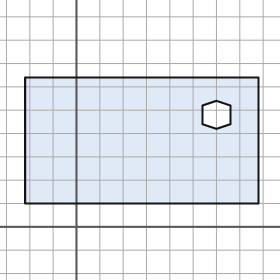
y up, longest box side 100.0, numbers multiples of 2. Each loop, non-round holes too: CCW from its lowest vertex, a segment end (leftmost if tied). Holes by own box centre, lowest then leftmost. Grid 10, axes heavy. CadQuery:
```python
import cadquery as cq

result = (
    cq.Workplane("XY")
    .moveTo(-22.0, 10.0)
    .lineTo(78.0, 10.0)
    .lineTo(78.0, 64.0)
    .lineTo(-22.0, 64.0)
    .close()
    .moveTo(60.0, 42.0)
    .lineTo(66.0, 44.0)
    .lineTo(66.0, 52.0)
    .lineTo(60.0, 54.0)
    .lineTo(54.0, 52.0)
    .lineTo(54.0, 44.0)
    .close()
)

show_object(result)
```